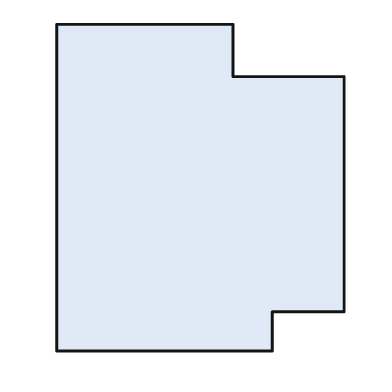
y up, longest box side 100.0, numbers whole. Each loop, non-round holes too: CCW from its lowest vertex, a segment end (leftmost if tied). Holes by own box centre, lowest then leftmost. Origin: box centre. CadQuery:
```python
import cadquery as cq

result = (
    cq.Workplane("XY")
    .moveTo(-44.0, -50.0)
    .lineTo(22.0, -50.0)
    .lineTo(22.0, -38.0)
    .lineTo(44.0, -38.0)
    .lineTo(44.0, 34.0)
    .lineTo(10.0, 34.0)
    .lineTo(10.0, 50.0)
    .lineTo(-44.0, 50.0)
    .close()
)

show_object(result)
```